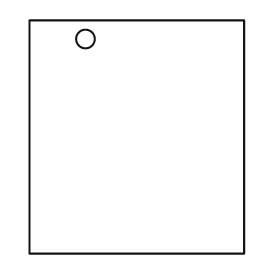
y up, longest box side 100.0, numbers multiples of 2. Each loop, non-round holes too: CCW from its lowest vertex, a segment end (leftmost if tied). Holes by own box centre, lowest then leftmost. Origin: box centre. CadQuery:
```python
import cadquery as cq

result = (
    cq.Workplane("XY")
    .moveTo(-46.0, -50.0)
    .lineTo(46.0, -50.0)
    .lineTo(46.0, 50.0)
    .lineTo(-46.0, 50.0)
    .close()
    .moveTo(-22.0, 42.0)
    .circle(4.0)
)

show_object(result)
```